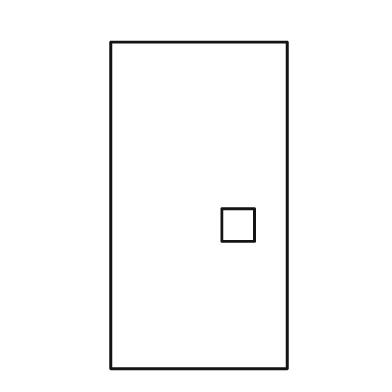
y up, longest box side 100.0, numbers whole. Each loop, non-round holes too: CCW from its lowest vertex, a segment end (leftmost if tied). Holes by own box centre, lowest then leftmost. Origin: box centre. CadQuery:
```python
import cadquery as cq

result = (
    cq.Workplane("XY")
    .moveTo(-27.0, -50.0)
    .lineTo(27.0, -50.0)
    .lineTo(27.0, 50.0)
    .lineTo(-27.0, 50.0)
    .close()
    .moveTo(7.0, -11.0)
    .lineTo(17.0, -11.0)
    .lineTo(17.0, -1.0)
    .lineTo(7.0, -1.0)
    .close()
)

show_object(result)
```